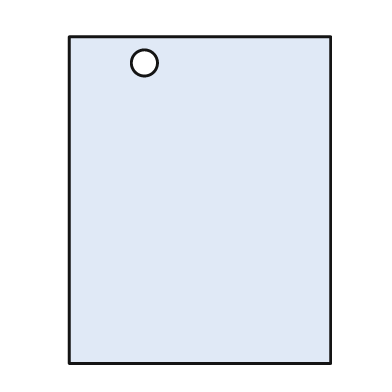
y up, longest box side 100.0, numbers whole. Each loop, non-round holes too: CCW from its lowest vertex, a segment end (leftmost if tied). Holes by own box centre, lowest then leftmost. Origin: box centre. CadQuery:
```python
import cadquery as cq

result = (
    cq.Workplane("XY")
    .moveTo(-40.0, -50.0)
    .lineTo(40.0, -50.0)
    .lineTo(40.0, 50.0)
    .lineTo(-40.0, 50.0)
    .close()
    .moveTo(-17.0, 42.0)
    .circle(4.0)
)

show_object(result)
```